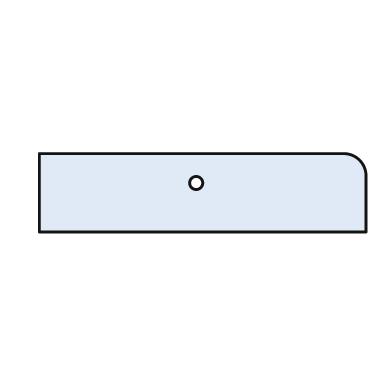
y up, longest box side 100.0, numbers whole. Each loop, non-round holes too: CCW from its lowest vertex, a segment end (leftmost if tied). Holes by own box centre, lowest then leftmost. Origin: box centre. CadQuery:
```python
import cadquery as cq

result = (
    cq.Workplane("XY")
    .moveTo(-50.0, -12.0)
    .lineTo(50.0, -12.0)
    .lineTo(50.0, 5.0)
    .threePointArc((48.0, 10.0), (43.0, 12.0))
    .lineTo(-50.0, 12.0)
    .close()
    .moveTo(-2.0, 3.0)
    .circle(2.0)
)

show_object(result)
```